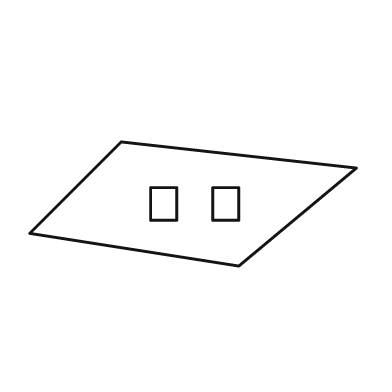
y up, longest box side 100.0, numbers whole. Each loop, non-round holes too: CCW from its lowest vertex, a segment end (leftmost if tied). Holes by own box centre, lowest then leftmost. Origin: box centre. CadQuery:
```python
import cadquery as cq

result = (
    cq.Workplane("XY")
    .moveTo(14.0, -19.0)
    .lineTo(50.0, 11.0)
    .lineTo(-22.0, 19.0)
    .lineTo(-50.0, -9.0)
    .close()
    .moveTo(-13.0, -5.0)
    .lineTo(-5.0, -5.0)
    .lineTo(-5.0, 5.0)
    .lineTo(-13.0, 5.0)
    .close()
    .moveTo(6.0, -5.0)
    .lineTo(14.0, -5.0)
    .lineTo(14.0, 5.0)
    .lineTo(6.0, 5.0)
    .close()
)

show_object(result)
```